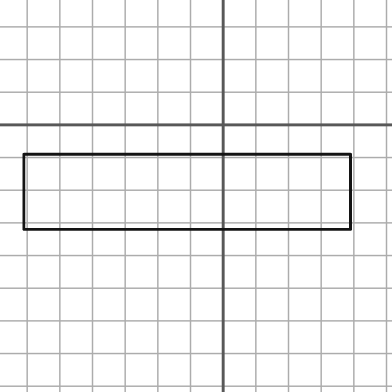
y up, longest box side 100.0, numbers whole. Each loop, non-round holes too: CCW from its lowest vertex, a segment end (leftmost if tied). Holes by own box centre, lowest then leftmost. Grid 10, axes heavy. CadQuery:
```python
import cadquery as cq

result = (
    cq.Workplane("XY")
    .moveTo(-61.0, -32.0)
    .lineTo(39.0, -32.0)
    .lineTo(39.0, -9.0)
    .lineTo(-61.0, -9.0)
    .close()
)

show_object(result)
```